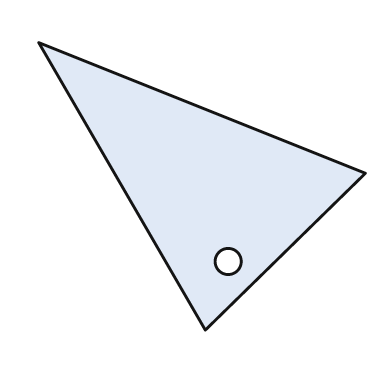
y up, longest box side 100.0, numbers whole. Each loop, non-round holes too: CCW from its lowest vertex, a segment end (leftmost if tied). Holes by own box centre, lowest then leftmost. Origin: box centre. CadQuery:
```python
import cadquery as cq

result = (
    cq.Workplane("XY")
    .moveTo(1.0, -44.0)
    .lineTo(50.0, 4.0)
    .lineTo(-50.0, 44.0)
    .close()
    .moveTo(8.0, -23.0)
    .circle(4.0)
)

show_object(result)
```